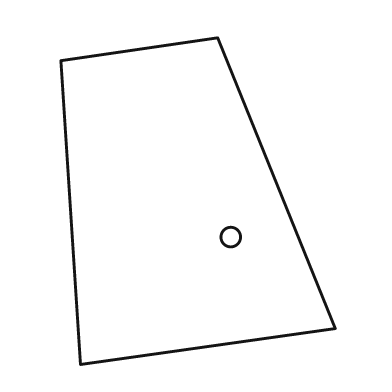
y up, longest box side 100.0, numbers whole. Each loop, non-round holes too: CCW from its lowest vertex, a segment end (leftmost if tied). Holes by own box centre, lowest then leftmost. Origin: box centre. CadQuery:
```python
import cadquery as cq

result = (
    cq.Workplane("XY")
    .moveTo(-36.0, -50.0)
    .lineTo(42.0, -39.0)
    .lineTo(6.0, 50.0)
    .lineTo(-42.0, 43.0)
    .close()
    .moveTo(10.0, -11.0)
    .circle(3.0)
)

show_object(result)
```